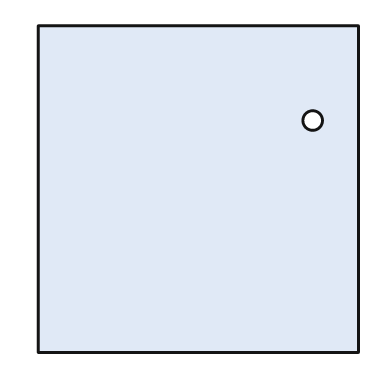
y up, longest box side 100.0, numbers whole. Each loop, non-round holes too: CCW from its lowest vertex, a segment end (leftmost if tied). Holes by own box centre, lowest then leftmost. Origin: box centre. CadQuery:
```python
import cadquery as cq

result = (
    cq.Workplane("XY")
    .moveTo(-49.0, -50.0)
    .lineTo(49.0, -50.0)
    .lineTo(49.0, 50.0)
    .lineTo(-49.0, 50.0)
    .close()
    .moveTo(35.0, 21.0)
    .circle(3.0)
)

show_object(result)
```